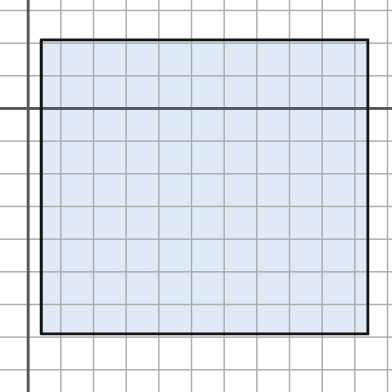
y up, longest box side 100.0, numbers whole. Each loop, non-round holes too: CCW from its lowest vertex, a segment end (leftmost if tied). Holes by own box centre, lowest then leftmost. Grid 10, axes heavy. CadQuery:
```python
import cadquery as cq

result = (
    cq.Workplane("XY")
    .moveTo(4.0, -69.0)
    .lineTo(104.0, -69.0)
    .lineTo(104.0, 21.0)
    .lineTo(4.0, 21.0)
    .close()
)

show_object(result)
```